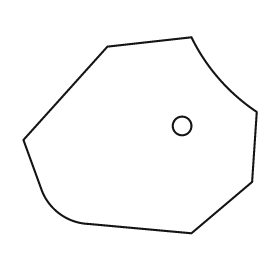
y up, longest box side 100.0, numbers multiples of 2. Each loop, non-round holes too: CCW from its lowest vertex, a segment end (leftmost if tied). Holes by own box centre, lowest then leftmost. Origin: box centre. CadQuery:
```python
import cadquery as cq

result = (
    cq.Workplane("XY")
    .moveTo(22.0, -42.0)
    .lineTo(48.0, -20.0)
    .lineTo(50.0, 10.0)
    .threePointArc((34.0, 24.0), (22.0, 42.0))
    .lineTo(-14.0, 38.0)
    .lineTo(-50.0, -2.0)
    .lineTo(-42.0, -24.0)
    .threePointArc((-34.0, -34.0), (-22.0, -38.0))
    .close()
    .moveTo(18.0, 4.0)
    .circle(4.0)
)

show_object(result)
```